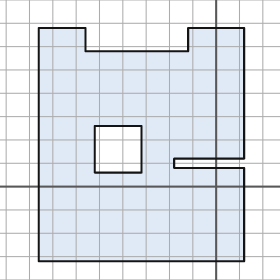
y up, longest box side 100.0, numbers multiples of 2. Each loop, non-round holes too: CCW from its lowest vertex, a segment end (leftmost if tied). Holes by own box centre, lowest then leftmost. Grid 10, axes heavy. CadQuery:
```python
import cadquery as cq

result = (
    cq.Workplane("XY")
    .moveTo(-76.0, -32.0)
    .lineTo(12.0, -32.0)
    .lineTo(12.0, 8.0)
    .lineTo(-18.0, 8.0)
    .lineTo(-18.0, 12.0)
    .lineTo(12.0, 12.0)
    .lineTo(12.0, 68.0)
    .lineTo(-12.0, 68.0)
    .lineTo(-12.0, 58.0)
    .lineTo(-56.0, 58.0)
    .lineTo(-56.0, 68.0)
    .lineTo(-76.0, 68.0)
    .close()
    .moveTo(-52.0, 6.0)
    .lineTo(-32.0, 6.0)
    .lineTo(-32.0, 26.0)
    .lineTo(-52.0, 26.0)
    .close()
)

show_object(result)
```